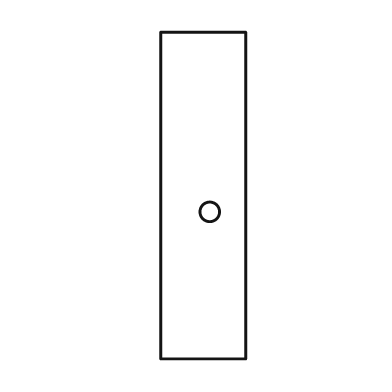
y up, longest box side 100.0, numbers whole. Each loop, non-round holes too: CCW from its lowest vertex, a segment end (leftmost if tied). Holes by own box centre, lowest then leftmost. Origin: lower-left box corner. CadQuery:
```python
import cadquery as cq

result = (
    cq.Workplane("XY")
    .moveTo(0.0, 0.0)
    .lineTo(26.0, 0.0)
    .lineTo(26.0, 100.0)
    .lineTo(0.0, 100.0)
    .close()
    .moveTo(15.0, 45.0)
    .circle(3.0)
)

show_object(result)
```